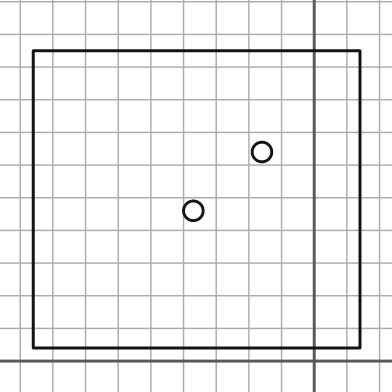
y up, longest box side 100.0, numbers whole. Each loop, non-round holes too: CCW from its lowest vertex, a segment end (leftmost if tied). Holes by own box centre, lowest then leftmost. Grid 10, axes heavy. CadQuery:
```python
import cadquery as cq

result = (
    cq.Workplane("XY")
    .moveTo(-86.0, 4.0)
    .lineTo(14.0, 4.0)
    .lineTo(14.0, 95.0)
    .lineTo(-86.0, 95.0)
    .close()
    .moveTo(-37.0, 46.0)
    .circle(3.0)
    .moveTo(-16.0, 64.0)
    .circle(3.0)
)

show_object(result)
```